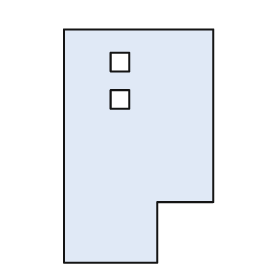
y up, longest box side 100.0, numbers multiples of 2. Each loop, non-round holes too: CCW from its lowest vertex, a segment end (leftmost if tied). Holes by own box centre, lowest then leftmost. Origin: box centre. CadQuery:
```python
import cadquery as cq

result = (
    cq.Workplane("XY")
    .moveTo(-32.0, -50.0)
    .lineTo(8.0, -50.0)
    .lineTo(8.0, -24.0)
    .lineTo(32.0, -24.0)
    .lineTo(32.0, 50.0)
    .lineTo(-32.0, 50.0)
    .close()
    .moveTo(-12.0, 16.0)
    .lineTo(-4.0, 16.0)
    .lineTo(-4.0, 24.0)
    .lineTo(-12.0, 24.0)
    .close()
    .moveTo(-12.0, 32.0)
    .lineTo(-4.0, 32.0)
    .lineTo(-4.0, 40.0)
    .lineTo(-12.0, 40.0)
    .close()
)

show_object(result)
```